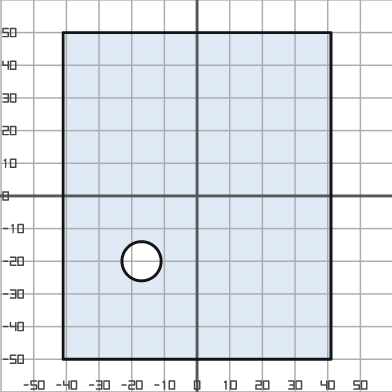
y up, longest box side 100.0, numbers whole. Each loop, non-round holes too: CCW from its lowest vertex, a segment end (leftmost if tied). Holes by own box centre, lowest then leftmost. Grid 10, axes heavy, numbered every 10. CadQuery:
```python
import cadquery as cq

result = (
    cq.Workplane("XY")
    .moveTo(-41.0, -50.0)
    .lineTo(41.0, -50.0)
    .lineTo(41.0, 50.0)
    .lineTo(-41.0, 50.0)
    .close()
    .moveTo(-17.0, -20.0)
    .circle(6.0)
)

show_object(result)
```